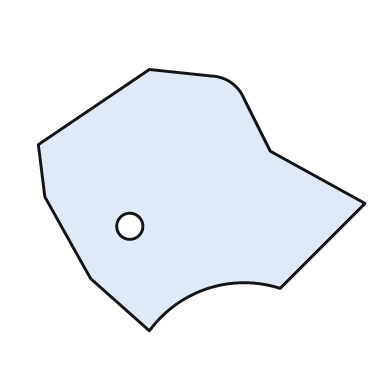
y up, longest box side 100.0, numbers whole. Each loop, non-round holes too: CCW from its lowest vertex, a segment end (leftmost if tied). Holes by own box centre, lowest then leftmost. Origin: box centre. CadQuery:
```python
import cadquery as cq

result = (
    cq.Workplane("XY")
    .moveTo(-16.0, -40.0)
    .threePointArc((2.0, -27.0), (24.0, -27.0))
    .lineTo(50.0, -1.0)
    .lineTo(21.0, 15.0)
    .lineTo(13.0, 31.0)
    .threePointArc((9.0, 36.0), (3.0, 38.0))
    .lineTo(-16.0, 40.0)
    .lineTo(-50.0, 17.0)
    .lineTo(-48.0, 1.0)
    .lineTo(-34.0, -24.0)
    .close()
    .moveTo(-22.0, -8.0)
    .circle(4.0)
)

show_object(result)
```